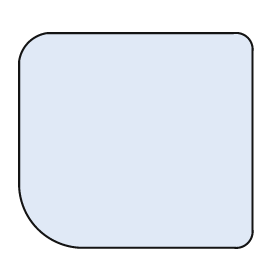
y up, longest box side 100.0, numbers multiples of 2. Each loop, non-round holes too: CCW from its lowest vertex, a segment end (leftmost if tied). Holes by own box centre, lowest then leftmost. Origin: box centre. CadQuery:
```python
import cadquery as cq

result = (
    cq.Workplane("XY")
    .moveTo(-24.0, -46.0)
    .lineTo(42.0, -46.0)
    .threePointArc((48.0, -44.0), (50.0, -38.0))
    .lineTo(50.0, 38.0)
    .threePointArc((48.0, 44.0), (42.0, 46.0))
    .lineTo(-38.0, 46.0)
    .threePointArc((-46.0, 42.0), (-50.0, 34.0))
    .lineTo(-50.0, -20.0)
    .threePointArc((-42.0, -38.0), (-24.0, -46.0))
    .close()
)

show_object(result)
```